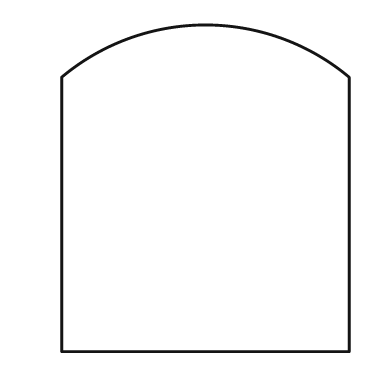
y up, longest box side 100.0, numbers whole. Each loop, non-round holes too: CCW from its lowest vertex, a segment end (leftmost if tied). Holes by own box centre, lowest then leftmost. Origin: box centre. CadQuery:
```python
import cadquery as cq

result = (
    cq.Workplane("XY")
    .moveTo(-44.0, -50.0)
    .lineTo(44.0, -50.0)
    .lineTo(44.0, 34.0)
    .threePointArc((0.0, 50.0), (-44.0, 34.0))
    .close()
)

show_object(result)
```